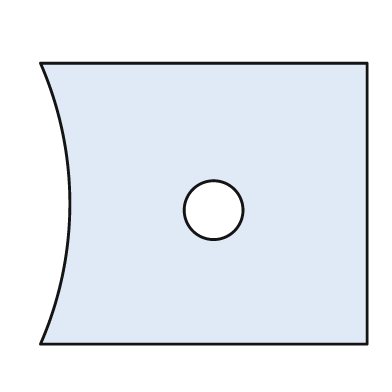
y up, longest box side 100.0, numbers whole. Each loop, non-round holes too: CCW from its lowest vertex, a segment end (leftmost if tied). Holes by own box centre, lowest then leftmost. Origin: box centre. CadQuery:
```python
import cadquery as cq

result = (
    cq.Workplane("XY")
    .moveTo(-50.0, -43.0)
    .lineTo(50.0, -43.0)
    .lineTo(50.0, 43.0)
    .lineTo(-50.0, 43.0)
    .threePointArc((-41.0, 0.0), (-50.0, -43.0))
    .close()
    .moveTo(3.0, -2.0)
    .circle(9.0)
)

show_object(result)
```